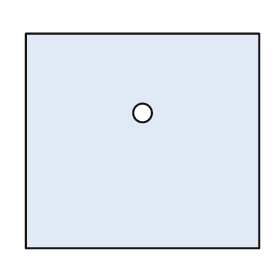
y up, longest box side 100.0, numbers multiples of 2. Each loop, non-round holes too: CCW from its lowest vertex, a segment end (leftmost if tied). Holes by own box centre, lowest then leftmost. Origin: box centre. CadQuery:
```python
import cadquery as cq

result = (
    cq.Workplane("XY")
    .moveTo(-50.0, -46.0)
    .lineTo(50.0, -46.0)
    .lineTo(50.0, 46.0)
    .lineTo(-50.0, 46.0)
    .close()
    .moveTo(0.0, 12.0)
    .circle(4.0)
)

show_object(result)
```